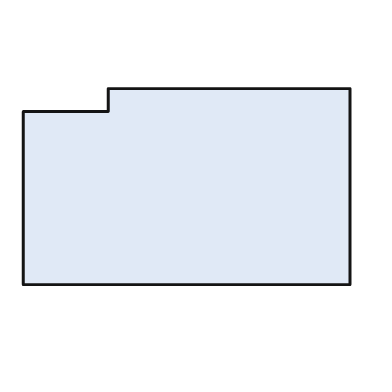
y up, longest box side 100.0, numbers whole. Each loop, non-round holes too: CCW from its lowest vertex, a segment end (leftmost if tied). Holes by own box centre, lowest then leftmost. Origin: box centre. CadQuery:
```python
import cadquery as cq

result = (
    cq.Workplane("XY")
    .moveTo(-50.0, -30.0)
    .lineTo(50.0, -30.0)
    .lineTo(50.0, 30.0)
    .lineTo(-24.0, 30.0)
    .lineTo(-24.0, 23.0)
    .lineTo(-50.0, 23.0)
    .close()
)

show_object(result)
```